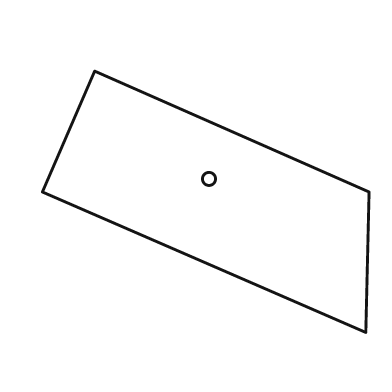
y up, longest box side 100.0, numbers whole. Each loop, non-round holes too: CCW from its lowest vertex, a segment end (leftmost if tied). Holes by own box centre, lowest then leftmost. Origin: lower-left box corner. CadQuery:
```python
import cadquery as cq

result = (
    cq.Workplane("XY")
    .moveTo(99.0, 0.0)
    .lineTo(100.0, 43.0)
    .lineTo(16.0, 80.0)
    .lineTo(0.0, 43.0)
    .close()
    .moveTo(51.0, 47.0)
    .circle(2.0)
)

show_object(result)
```